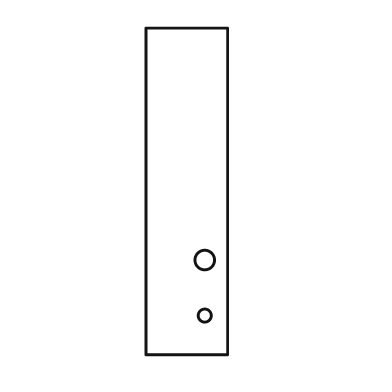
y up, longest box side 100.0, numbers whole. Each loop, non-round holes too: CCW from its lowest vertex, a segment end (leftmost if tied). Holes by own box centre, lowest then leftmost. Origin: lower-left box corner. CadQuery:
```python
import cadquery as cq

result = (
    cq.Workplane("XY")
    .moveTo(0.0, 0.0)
    .lineTo(25.0, 0.0)
    .lineTo(25.0, 100.0)
    .lineTo(0.0, 100.0)
    .close()
    .moveTo(18.0, 12.0)
    .circle(2.0)
    .moveTo(18.0, 29.0)
    .circle(3.0)
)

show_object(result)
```